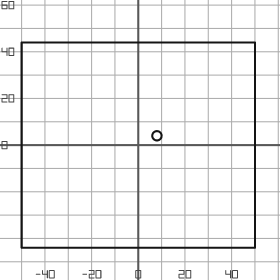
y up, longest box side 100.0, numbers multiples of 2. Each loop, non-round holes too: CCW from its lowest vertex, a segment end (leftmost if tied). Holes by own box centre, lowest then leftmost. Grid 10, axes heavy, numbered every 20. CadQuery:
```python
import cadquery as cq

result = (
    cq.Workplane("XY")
    .moveTo(-50.0, -44.0)
    .lineTo(50.0, -44.0)
    .lineTo(50.0, 44.0)
    .lineTo(-50.0, 44.0)
    .close()
    .moveTo(8.0, 4.0)
    .circle(2.0)
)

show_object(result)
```